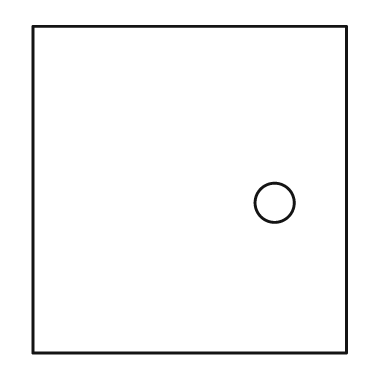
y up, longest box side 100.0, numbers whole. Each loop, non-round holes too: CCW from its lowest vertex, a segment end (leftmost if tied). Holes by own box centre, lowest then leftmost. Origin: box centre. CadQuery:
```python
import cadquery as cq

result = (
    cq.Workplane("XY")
    .moveTo(-48.0, -50.0)
    .lineTo(48.0, -50.0)
    .lineTo(48.0, 50.0)
    .lineTo(-48.0, 50.0)
    .close()
    .moveTo(26.0, -4.0)
    .circle(6.0)
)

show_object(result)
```